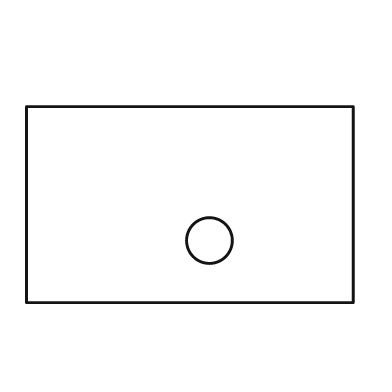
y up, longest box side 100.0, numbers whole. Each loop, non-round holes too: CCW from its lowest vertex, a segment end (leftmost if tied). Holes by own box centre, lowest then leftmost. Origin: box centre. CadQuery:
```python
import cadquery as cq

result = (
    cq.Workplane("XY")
    .moveTo(-50.0, -30.0)
    .lineTo(50.0, -30.0)
    .lineTo(50.0, 30.0)
    .lineTo(-50.0, 30.0)
    .close()
    .moveTo(6.0, -11.0)
    .circle(7.0)
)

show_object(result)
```